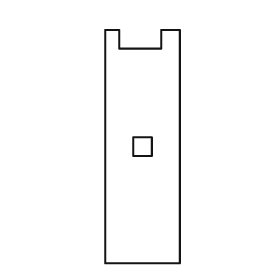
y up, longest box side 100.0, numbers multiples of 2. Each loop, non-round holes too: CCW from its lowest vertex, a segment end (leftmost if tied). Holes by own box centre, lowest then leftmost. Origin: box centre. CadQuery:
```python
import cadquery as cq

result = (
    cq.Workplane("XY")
    .moveTo(-16.0, -50.0)
    .lineTo(16.0, -50.0)
    .lineTo(16.0, 50.0)
    .lineTo(8.0, 50.0)
    .lineTo(8.0, 42.0)
    .lineTo(-10.0, 42.0)
    .lineTo(-10.0, 50.0)
    .lineTo(-16.0, 50.0)
    .close()
    .moveTo(-4.0, -4.0)
    .lineTo(4.0, -4.0)
    .lineTo(4.0, 4.0)
    .lineTo(-4.0, 4.0)
    .close()
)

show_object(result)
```